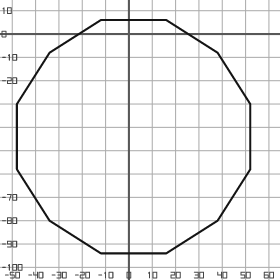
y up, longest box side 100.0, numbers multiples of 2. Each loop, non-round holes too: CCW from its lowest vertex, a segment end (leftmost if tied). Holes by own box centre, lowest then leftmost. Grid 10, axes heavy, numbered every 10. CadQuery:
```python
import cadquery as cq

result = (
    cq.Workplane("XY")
    .moveTo(-12.0, -94.0)
    .lineTo(16.0, -94.0)
    .lineTo(38.0, -80.0)
    .lineTo(52.0, -58.0)
    .lineTo(52.0, -30.0)
    .lineTo(38.0, -8.0)
    .lineTo(16.0, 6.0)
    .lineTo(-12.0, 6.0)
    .lineTo(-34.0, -8.0)
    .lineTo(-48.0, -30.0)
    .lineTo(-48.0, -58.0)
    .lineTo(-34.0, -80.0)
    .close()
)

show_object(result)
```